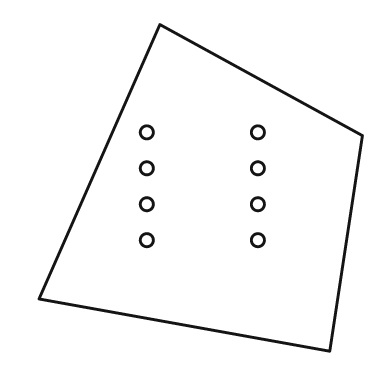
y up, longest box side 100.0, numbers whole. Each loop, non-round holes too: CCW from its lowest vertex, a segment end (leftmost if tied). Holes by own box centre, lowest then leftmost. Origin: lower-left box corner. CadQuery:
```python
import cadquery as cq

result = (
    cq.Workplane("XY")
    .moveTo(89.0, 0.0)
    .lineTo(99.0, 66.0)
    .lineTo(37.0, 100.0)
    .lineTo(0.0, 16.0)
    .close()
    .moveTo(33.0, 34.0)
    .circle(2.0)
    .moveTo(67.0, 34.0)
    .circle(2.0)
    .moveTo(33.0, 45.0)
    .circle(2.0)
    .moveTo(67.0, 45.0)
    .circle(2.0)
    .moveTo(33.0, 56.0)
    .circle(2.0)
    .moveTo(67.0, 56.0)
    .circle(2.0)
    .moveTo(33.0, 67.0)
    .circle(2.0)
    .moveTo(67.0, 67.0)
    .circle(2.0)
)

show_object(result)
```